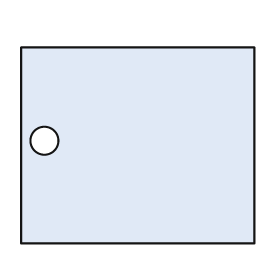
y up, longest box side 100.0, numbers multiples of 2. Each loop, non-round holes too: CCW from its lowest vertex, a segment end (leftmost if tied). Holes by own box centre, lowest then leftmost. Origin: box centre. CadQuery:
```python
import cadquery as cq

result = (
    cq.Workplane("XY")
    .moveTo(-50.0, -42.0)
    .lineTo(50.0, -42.0)
    .lineTo(50.0, 42.0)
    .lineTo(-50.0, 42.0)
    .close()
    .moveTo(-40.0, 2.0)
    .circle(6.0)
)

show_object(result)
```